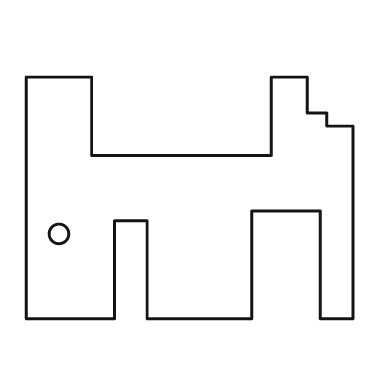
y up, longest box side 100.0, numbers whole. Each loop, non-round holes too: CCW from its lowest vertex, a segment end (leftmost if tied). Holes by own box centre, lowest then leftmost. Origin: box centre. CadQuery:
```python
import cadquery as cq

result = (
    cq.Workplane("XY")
    .moveTo(-50.0, -37.0)
    .lineTo(-23.0, -37.0)
    .lineTo(-23.0, -7.0)
    .lineTo(-13.0, -7.0)
    .lineTo(-13.0, -37.0)
    .lineTo(19.0, -37.0)
    .lineTo(19.0, -4.0)
    .lineTo(40.0, -4.0)
    .lineTo(40.0, -37.0)
    .lineTo(50.0, -37.0)
    .lineTo(50.0, 22.0)
    .lineTo(42.0, 22.0)
    .lineTo(42.0, 26.0)
    .lineTo(36.0, 26.0)
    .lineTo(36.0, 37.0)
    .lineTo(25.0, 37.0)
    .lineTo(25.0, 13.0)
    .lineTo(-30.0, 13.0)
    .lineTo(-30.0, 37.0)
    .lineTo(-50.0, 37.0)
    .close()
    .moveTo(-40.0, -11.0)
    .circle(3.0)
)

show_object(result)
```